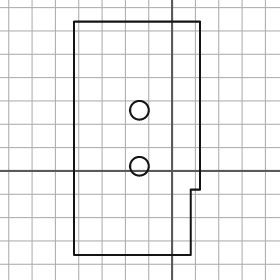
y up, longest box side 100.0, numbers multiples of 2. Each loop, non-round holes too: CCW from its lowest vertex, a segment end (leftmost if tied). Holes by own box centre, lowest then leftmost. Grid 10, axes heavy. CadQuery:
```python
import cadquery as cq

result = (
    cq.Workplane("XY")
    .moveTo(-42.0, -36.0)
    .lineTo(8.0, -36.0)
    .lineTo(8.0, -8.0)
    .lineTo(12.0, -8.0)
    .lineTo(12.0, 64.0)
    .lineTo(-42.0, 64.0)
    .close()
    .moveTo(-14.0, 2.0)
    .circle(4.0)
    .moveTo(-14.0, 26.0)
    .circle(4.0)
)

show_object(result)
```